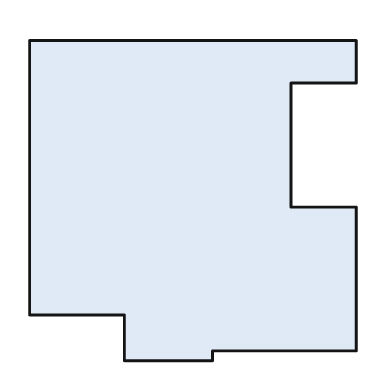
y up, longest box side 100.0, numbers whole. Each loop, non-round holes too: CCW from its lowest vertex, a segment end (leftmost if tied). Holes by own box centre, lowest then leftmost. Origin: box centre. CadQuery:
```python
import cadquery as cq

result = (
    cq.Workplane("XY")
    .moveTo(-21.0, -49.0)
    .lineTo(6.0, -49.0)
    .lineTo(6.0, -46.0)
    .lineTo(50.0, -46.0)
    .lineTo(50.0, -2.0)
    .lineTo(30.0, -2.0)
    .lineTo(30.0, 36.0)
    .lineTo(50.0, 36.0)
    .lineTo(50.0, 49.0)
    .lineTo(-50.0, 49.0)
    .lineTo(-50.0, -35.0)
    .lineTo(-21.0, -35.0)
    .close()
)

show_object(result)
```